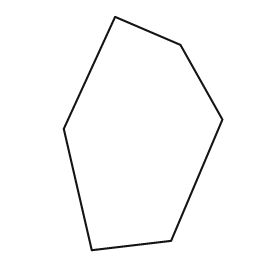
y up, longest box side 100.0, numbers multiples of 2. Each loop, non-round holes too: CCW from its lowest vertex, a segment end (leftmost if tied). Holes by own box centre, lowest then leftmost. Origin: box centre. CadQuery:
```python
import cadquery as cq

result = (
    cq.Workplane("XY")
    .moveTo(-22.0, -50.0)
    .lineTo(12.0, -46.0)
    .lineTo(34.0, 6.0)
    .lineTo(16.0, 38.0)
    .lineTo(-12.0, 50.0)
    .lineTo(-34.0, 2.0)
    .close()
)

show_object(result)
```